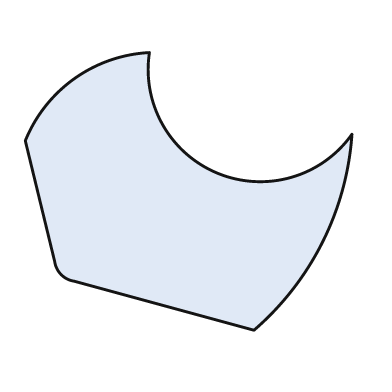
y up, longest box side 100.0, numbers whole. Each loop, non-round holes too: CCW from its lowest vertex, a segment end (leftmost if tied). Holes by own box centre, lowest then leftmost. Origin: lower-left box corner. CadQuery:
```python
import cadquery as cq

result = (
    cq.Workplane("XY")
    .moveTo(70.0, 0.0)
    .threePointArc((91.0, 27.0), (100.0, 60.0))
    .threePointArc((59.0, 48.0), (38.0, 85.0))
    .threePointArc((15.0, 77.0), (0.0, 58.0))
    .lineTo(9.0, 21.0)
    .threePointArc((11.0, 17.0), (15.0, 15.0))
    .close()
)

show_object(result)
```